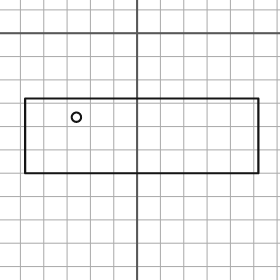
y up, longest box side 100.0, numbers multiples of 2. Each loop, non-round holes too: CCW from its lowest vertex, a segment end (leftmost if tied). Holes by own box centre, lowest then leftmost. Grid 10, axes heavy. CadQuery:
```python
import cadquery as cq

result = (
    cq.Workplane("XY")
    .moveTo(-48.0, -60.0)
    .lineTo(52.0, -60.0)
    .lineTo(52.0, -28.0)
    .lineTo(-48.0, -28.0)
    .close()
    .moveTo(-26.0, -36.0)
    .circle(2.0)
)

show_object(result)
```